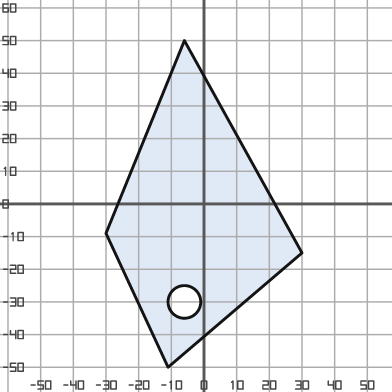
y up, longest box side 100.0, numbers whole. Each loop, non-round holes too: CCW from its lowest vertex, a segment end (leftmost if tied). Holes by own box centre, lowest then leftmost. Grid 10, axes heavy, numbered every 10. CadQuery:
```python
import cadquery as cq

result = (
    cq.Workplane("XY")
    .moveTo(-11.0, -50.0)
    .lineTo(30.0, -15.0)
    .lineTo(-6.0, 50.0)
    .lineTo(-30.0, -9.0)
    .close()
    .moveTo(-6.0, -30.0)
    .circle(5.0)
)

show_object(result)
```